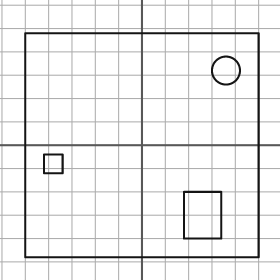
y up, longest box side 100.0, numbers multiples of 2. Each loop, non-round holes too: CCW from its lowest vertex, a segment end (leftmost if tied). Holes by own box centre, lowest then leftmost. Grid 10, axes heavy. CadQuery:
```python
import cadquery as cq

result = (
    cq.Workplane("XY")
    .moveTo(-50.0, -48.0)
    .lineTo(50.0, -48.0)
    .lineTo(50.0, 48.0)
    .lineTo(-50.0, 48.0)
    .close()
    .moveTo(18.0, -40.0)
    .lineTo(34.0, -40.0)
    .lineTo(34.0, -20.0)
    .lineTo(18.0, -20.0)
    .close()
    .moveTo(-42.0, -12.0)
    .lineTo(-34.0, -12.0)
    .lineTo(-34.0, -4.0)
    .lineTo(-42.0, -4.0)
    .close()
    .moveTo(36.0, 32.0)
    .circle(6.0)
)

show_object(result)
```